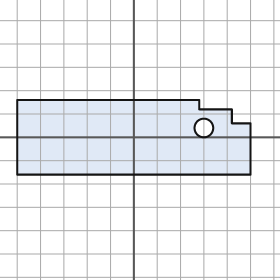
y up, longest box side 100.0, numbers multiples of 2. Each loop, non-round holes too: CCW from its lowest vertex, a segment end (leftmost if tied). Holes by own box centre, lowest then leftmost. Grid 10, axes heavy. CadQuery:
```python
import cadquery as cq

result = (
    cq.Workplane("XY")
    .moveTo(-50.0, -16.0)
    .lineTo(50.0, -16.0)
    .lineTo(50.0, 6.0)
    .lineTo(42.0, 6.0)
    .lineTo(42.0, 12.0)
    .lineTo(28.0, 12.0)
    .lineTo(28.0, 16.0)
    .lineTo(-50.0, 16.0)
    .close()
    .moveTo(30.0, 4.0)
    .circle(4.0)
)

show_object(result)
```